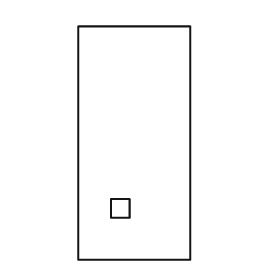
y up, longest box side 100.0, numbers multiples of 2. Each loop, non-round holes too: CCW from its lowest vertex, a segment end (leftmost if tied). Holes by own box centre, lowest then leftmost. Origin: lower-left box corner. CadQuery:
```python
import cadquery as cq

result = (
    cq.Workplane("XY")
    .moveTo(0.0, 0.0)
    .lineTo(48.0, 0.0)
    .lineTo(48.0, 100.0)
    .lineTo(0.0, 100.0)
    .close()
    .moveTo(14.0, 18.0)
    .lineTo(22.0, 18.0)
    .lineTo(22.0, 26.0)
    .lineTo(14.0, 26.0)
    .close()
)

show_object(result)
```